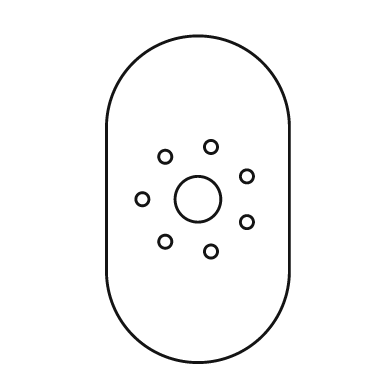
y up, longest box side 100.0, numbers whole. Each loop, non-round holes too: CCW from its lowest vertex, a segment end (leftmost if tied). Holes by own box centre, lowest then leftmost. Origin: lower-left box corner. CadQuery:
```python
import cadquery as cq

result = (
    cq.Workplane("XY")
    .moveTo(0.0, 28.0)
    .threePointArc((28.0, 0.0), (56.0, 28.0))
    .lineTo(56.0, 72.0)
    .threePointArc((28.0, 100.0), (0.0, 72.0))
    .close()
    .moveTo(32.0, 34.0)
    .circle(2.0)
    .moveTo(18.0, 37.0)
    .circle(2.0)
    .moveTo(43.0, 43.0)
    .circle(2.0)
    .moveTo(11.0, 50.0)
    .circle(2.0)
    .moveTo(28.0, 50.0)
    .circle(7.0)
    .moveTo(43.0, 57.0)
    .circle(2.0)
    .moveTo(18.0, 63.0)
    .circle(2.0)
    .moveTo(32.0, 66.0)
    .circle(2.0)
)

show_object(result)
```